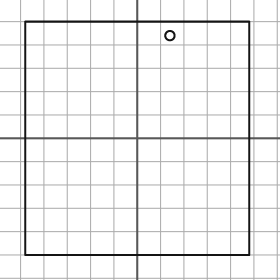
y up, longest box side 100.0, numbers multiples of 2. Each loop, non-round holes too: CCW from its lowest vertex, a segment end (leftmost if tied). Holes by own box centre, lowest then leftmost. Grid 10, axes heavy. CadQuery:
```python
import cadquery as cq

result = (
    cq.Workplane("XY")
    .moveTo(-48.0, -50.0)
    .lineTo(48.0, -50.0)
    .lineTo(48.0, 50.0)
    .lineTo(-48.0, 50.0)
    .close()
    .moveTo(14.0, 44.0)
    .circle(2.0)
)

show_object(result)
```